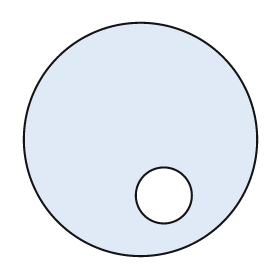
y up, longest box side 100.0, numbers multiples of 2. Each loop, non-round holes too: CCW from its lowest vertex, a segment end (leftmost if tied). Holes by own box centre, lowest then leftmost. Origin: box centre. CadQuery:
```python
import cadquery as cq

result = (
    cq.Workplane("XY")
    .moveTo(0.0, 0.0)
    .circle(50.0)
    .moveTo(10.0, -24.0)
    .circle(12.0)
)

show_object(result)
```